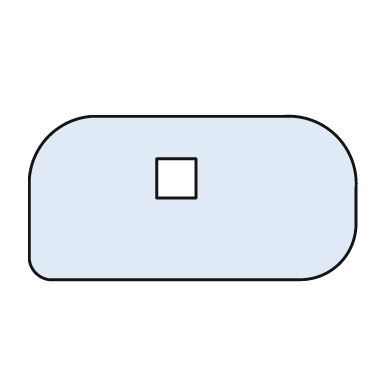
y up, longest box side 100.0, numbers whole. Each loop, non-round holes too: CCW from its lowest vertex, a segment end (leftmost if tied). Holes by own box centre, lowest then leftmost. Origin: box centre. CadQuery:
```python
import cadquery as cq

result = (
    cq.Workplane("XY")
    .moveTo(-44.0, -25.0)
    .lineTo(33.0, -25.0)
    .threePointArc((45.0, -20.0), (50.0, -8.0))
    .lineTo(50.0, 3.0)
    .threePointArc((44.0, 19.0), (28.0, 25.0))
    .lineTo(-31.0, 25.0)
    .threePointArc((-44.0, 19.0), (-50.0, 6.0))
    .lineTo(-50.0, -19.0)
    .threePointArc((-48.0, -23.0), (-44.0, -25.0))
    .close()
    .moveTo(-11.0, 0.0)
    .lineTo(1.0, 0.0)
    .lineTo(1.0, 12.0)
    .lineTo(-11.0, 12.0)
    .close()
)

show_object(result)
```